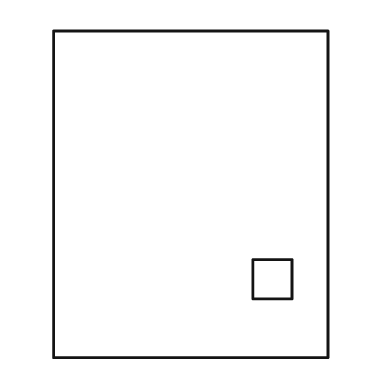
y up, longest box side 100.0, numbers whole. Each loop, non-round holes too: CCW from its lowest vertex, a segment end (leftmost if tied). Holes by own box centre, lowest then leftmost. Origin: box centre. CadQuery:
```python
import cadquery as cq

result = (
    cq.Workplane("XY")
    .moveTo(-42.0, -50.0)
    .lineTo(42.0, -50.0)
    .lineTo(42.0, 50.0)
    .lineTo(-42.0, 50.0)
    .close()
    .moveTo(19.0, -32.0)
    .lineTo(31.0, -32.0)
    .lineTo(31.0, -20.0)
    .lineTo(19.0, -20.0)
    .close()
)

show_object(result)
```